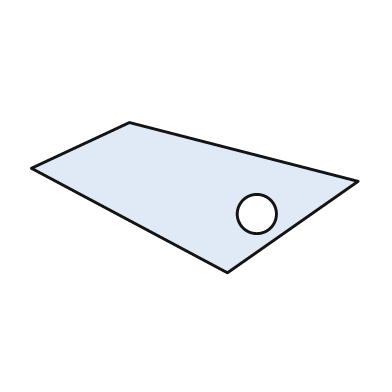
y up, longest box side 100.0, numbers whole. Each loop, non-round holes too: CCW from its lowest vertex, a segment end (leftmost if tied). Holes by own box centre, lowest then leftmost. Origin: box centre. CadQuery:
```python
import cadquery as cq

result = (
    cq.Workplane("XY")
    .moveTo(10.0, -23.0)
    .lineTo(50.0, 5.0)
    .lineTo(-20.0, 23.0)
    .lineTo(-50.0, 9.0)
    .close()
    .moveTo(19.0, -5.0)
    .circle(6.0)
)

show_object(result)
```